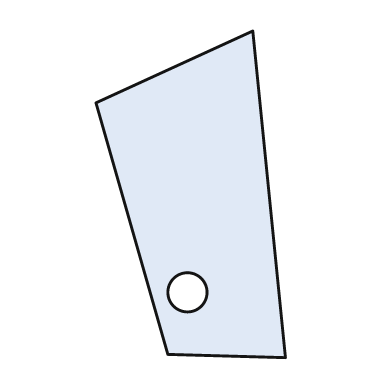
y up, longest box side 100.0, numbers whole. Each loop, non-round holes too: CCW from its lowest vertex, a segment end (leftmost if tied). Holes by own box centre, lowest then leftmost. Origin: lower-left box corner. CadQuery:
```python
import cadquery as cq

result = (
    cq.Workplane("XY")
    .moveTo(58.0, 0.0)
    .lineTo(48.0, 100.0)
    .lineTo(0.0, 78.0)
    .lineTo(22.0, 1.0)
    .close()
    .moveTo(28.0, 20.0)
    .circle(6.0)
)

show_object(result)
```